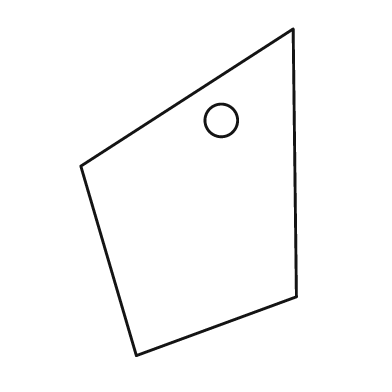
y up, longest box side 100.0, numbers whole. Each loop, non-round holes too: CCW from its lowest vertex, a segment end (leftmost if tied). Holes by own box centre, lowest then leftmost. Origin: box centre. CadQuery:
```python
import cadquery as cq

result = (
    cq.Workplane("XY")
    .moveTo(-16.0, -50.0)
    .lineTo(33.0, -32.0)
    .lineTo(32.0, 50.0)
    .lineTo(-33.0, 8.0)
    .close()
    .moveTo(10.0, 22.0)
    .circle(5.0)
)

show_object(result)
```